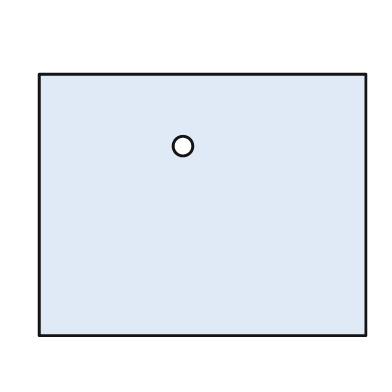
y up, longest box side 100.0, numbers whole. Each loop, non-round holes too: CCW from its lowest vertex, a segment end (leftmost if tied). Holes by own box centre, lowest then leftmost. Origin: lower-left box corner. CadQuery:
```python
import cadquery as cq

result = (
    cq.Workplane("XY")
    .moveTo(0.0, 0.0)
    .lineTo(100.0, 0.0)
    .lineTo(100.0, 80.0)
    .lineTo(0.0, 80.0)
    .close()
    .moveTo(44.0, 58.0)
    .circle(3.0)
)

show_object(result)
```